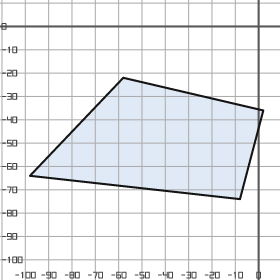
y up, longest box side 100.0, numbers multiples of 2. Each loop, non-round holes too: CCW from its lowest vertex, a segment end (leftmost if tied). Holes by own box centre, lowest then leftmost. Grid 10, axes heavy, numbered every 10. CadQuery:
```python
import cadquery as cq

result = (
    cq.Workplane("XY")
    .moveTo(-8.0, -74.0)
    .lineTo(2.0, -36.0)
    .lineTo(-58.0, -22.0)
    .lineTo(-98.0, -64.0)
    .close()
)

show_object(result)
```